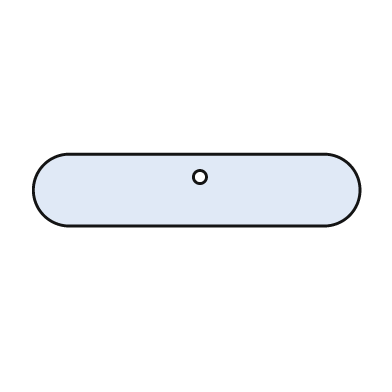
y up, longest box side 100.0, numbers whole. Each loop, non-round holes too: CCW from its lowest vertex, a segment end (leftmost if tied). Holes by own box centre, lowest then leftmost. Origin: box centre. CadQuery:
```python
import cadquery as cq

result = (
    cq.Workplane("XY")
    .moveTo(-39.0, -11.0)
    .lineTo(39.0, -11.0)
    .threePointArc((50.0, 0.0), (39.0, 11.0))
    .lineTo(-39.0, 11.0)
    .threePointArc((-50.0, 0.0), (-39.0, -11.0))
    .close()
    .moveTo(1.0, 4.0)
    .circle(2.0)
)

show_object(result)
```